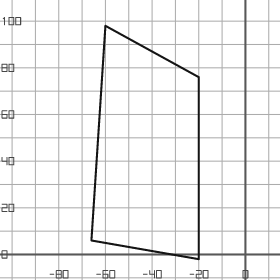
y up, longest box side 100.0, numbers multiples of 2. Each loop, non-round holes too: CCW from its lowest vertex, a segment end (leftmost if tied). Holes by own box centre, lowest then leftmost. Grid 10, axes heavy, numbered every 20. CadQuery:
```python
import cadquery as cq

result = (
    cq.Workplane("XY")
    .moveTo(-20.0, -2.0)
    .lineTo(-20.0, 76.0)
    .lineTo(-60.0, 98.0)
    .lineTo(-66.0, 6.0)
    .close()
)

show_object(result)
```